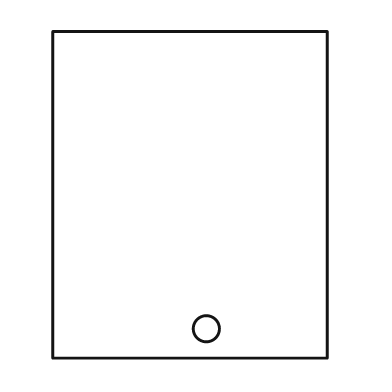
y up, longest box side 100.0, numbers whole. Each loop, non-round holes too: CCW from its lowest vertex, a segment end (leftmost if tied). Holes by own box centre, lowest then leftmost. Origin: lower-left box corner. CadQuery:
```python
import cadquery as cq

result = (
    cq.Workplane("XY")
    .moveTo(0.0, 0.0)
    .lineTo(84.0, 0.0)
    .lineTo(84.0, 100.0)
    .lineTo(0.0, 100.0)
    .close()
    .moveTo(47.0, 9.0)
    .circle(4.0)
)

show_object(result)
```